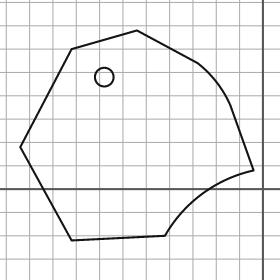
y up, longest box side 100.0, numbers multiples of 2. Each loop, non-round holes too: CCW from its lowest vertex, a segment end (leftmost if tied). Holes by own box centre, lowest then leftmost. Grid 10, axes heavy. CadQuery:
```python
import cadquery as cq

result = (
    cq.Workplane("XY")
    .moveTo(-82.0, -22.0)
    .lineTo(-42.0, -20.0)
    .threePointArc((-26.0, -2.0), (-4.0, 8.0))
    .lineTo(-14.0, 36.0)
    .threePointArc((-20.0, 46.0), (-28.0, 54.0))
    .lineTo(-54.0, 68.0)
    .lineTo(-82.0, 60.0)
    .lineTo(-104.0, 18.0)
    .close()
    .moveTo(-68.0, 48.0)
    .circle(4.0)
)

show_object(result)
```